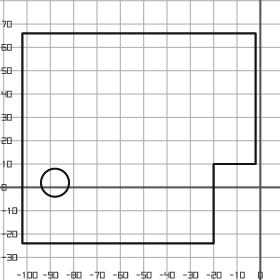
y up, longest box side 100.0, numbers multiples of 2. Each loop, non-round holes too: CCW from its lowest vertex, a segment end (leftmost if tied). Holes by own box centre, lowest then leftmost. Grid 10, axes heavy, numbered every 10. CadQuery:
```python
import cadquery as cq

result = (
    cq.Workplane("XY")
    .moveTo(-102.0, -24.0)
    .lineTo(-20.0, -24.0)
    .lineTo(-20.0, 10.0)
    .lineTo(-2.0, 10.0)
    .lineTo(-2.0, 66.0)
    .lineTo(-102.0, 66.0)
    .close()
    .moveTo(-88.0, 2.0)
    .circle(6.0)
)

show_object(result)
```